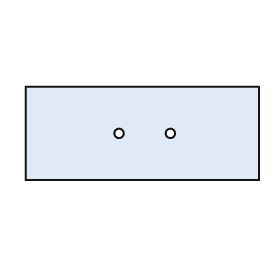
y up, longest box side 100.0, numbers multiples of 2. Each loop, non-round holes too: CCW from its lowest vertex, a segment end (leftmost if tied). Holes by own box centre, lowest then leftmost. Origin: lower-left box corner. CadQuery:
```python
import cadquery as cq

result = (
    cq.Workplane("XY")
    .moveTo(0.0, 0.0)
    .lineTo(100.0, 0.0)
    .lineTo(100.0, 40.0)
    .lineTo(0.0, 40.0)
    .close()
    .moveTo(40.0, 20.0)
    .circle(2.0)
    .moveTo(62.0, 20.0)
    .circle(2.0)
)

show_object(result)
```